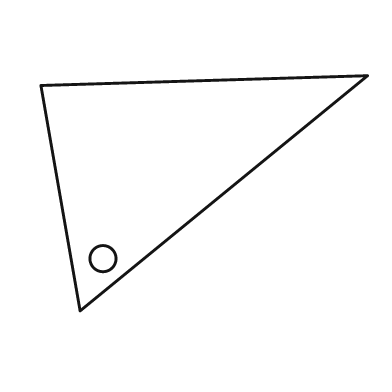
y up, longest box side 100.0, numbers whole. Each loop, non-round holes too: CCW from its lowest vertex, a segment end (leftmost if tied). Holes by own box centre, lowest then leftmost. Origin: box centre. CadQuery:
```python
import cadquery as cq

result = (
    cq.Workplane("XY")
    .moveTo(-38.0, -36.0)
    .lineTo(50.0, 36.0)
    .lineTo(-50.0, 33.0)
    .close()
    .moveTo(-31.0, -20.0)
    .circle(4.0)
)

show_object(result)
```